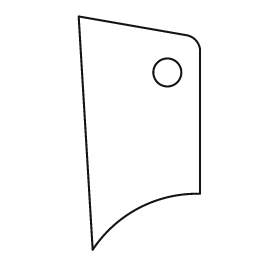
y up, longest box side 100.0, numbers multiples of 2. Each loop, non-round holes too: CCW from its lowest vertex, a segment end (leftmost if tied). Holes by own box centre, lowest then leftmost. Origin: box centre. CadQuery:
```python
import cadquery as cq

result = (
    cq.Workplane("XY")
    .moveTo(-20.0, -50.0)
    .threePointArc((0.0, -32.0), (26.0, -26.0))
    .lineTo(26.0, 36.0)
    .threePointArc((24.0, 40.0), (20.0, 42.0))
    .lineTo(-26.0, 50.0)
    .close()
    .moveTo(12.0, 26.0)
    .circle(6.0)
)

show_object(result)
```